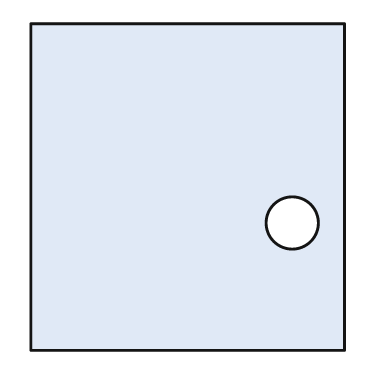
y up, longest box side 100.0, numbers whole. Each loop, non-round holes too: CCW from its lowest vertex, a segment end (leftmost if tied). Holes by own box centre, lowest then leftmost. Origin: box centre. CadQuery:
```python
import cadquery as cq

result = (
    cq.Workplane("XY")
    .moveTo(-48.0, -50.0)
    .lineTo(48.0, -50.0)
    .lineTo(48.0, 50.0)
    .lineTo(-48.0, 50.0)
    .close()
    .moveTo(32.0, -11.0)
    .circle(8.0)
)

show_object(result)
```